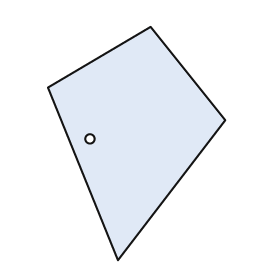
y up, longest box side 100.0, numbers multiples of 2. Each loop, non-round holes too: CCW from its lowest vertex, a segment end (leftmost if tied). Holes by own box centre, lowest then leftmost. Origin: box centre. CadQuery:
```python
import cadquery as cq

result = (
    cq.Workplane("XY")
    .moveTo(-8.0, -50.0)
    .lineTo(38.0, 10.0)
    .lineTo(6.0, 50.0)
    .lineTo(-38.0, 24.0)
    .close()
    .moveTo(-20.0, 2.0)
    .circle(2.0)
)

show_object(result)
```